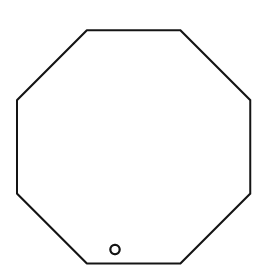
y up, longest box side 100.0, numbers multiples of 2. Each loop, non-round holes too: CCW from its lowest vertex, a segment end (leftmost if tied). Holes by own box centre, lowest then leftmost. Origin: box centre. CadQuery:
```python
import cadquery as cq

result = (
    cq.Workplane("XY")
    .moveTo(-20.0, -50.0)
    .lineTo(20.0, -50.0)
    .lineTo(50.0, -20.0)
    .lineTo(50.0, 20.0)
    .lineTo(20.0, 50.0)
    .lineTo(-20.0, 50.0)
    .lineTo(-50.0, 20.0)
    .lineTo(-50.0, -20.0)
    .close()
    .moveTo(-8.0, -44.0)
    .circle(2.0)
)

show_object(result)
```